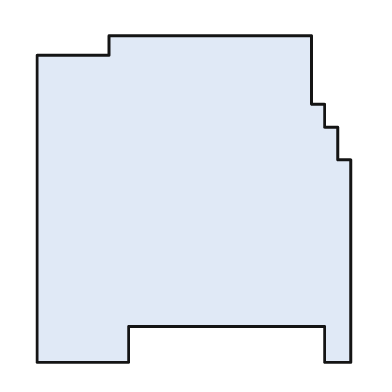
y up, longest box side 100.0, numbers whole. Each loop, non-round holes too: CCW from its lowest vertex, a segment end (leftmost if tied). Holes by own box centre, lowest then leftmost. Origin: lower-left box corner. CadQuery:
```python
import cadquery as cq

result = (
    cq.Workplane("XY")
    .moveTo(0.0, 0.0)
    .lineTo(28.0, 0.0)
    .lineTo(28.0, 11.0)
    .lineTo(88.0, 11.0)
    .lineTo(88.0, 0.0)
    .lineTo(96.0, 0.0)
    .lineTo(96.0, 62.0)
    .lineTo(92.0, 62.0)
    .lineTo(92.0, 72.0)
    .lineTo(88.0, 72.0)
    .lineTo(88.0, 79.0)
    .lineTo(84.0, 79.0)
    .lineTo(84.0, 100.0)
    .lineTo(22.0, 100.0)
    .lineTo(22.0, 94.0)
    .lineTo(0.0, 94.0)
    .close()
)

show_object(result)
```